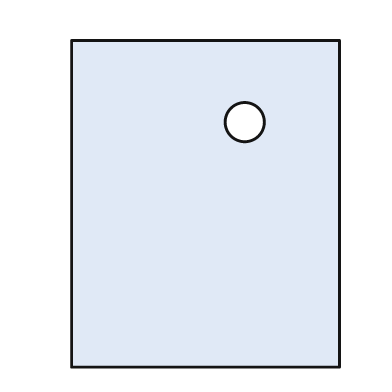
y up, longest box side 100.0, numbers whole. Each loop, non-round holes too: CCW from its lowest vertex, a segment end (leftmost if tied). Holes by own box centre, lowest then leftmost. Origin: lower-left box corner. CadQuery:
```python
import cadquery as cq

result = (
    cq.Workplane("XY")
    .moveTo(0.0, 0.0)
    .lineTo(82.0, 0.0)
    .lineTo(82.0, 100.0)
    .lineTo(0.0, 100.0)
    .close()
    .moveTo(53.0, 75.0)
    .circle(6.0)
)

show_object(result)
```